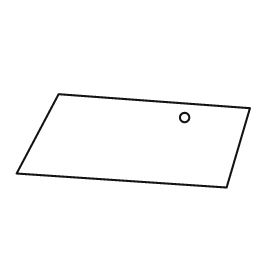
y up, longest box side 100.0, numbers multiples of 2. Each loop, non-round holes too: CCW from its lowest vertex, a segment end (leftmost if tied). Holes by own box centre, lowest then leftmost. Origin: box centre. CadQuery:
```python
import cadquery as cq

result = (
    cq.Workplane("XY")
    .moveTo(40.0, -20.0)
    .lineTo(50.0, 14.0)
    .lineTo(-32.0, 20.0)
    .lineTo(-50.0, -14.0)
    .close()
    .moveTo(22.0, 10.0)
    .circle(2.0)
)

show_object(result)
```